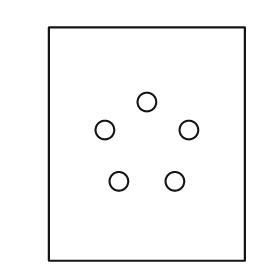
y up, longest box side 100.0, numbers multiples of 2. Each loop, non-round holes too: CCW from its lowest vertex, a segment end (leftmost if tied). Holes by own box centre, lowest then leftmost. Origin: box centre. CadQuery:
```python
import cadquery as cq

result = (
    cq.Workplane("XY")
    .moveTo(-42.0, -50.0)
    .lineTo(42.0, -50.0)
    .lineTo(42.0, 50.0)
    .lineTo(-42.0, 50.0)
    .close()
    .moveTo(-12.0, -16.0)
    .circle(4.0)
    .moveTo(12.0, -16.0)
    .circle(4.0)
    .moveTo(-18.0, 6.0)
    .circle(4.0)
    .moveTo(18.0, 6.0)
    .circle(4.0)
    .moveTo(0.0, 18.0)
    .circle(4.0)
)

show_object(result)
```